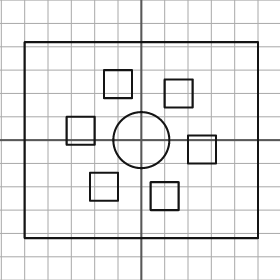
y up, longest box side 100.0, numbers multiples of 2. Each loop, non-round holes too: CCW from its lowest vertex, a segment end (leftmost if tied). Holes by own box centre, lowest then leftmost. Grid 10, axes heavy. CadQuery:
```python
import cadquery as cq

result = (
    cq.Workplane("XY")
    .moveTo(-50.0, -42.0)
    .lineTo(50.0, -42.0)
    .lineTo(50.0, 42.0)
    .lineTo(-50.0, 42.0)
    .close()
    .moveTo(4.0, -30.0)
    .lineTo(16.0, -30.0)
    .lineTo(16.0, -18.0)
    .lineTo(4.0, -18.0)
    .close()
    .moveTo(-22.0, -26.0)
    .lineTo(-10.0, -26.0)
    .lineTo(-10.0, -14.0)
    .lineTo(-22.0, -14.0)
    .close()
    .moveTo(20.0, -10.0)
    .lineTo(32.0, -10.0)
    .lineTo(32.0, 2.0)
    .lineTo(20.0, 2.0)
    .close()
    .moveTo(0.0, 0.0)
    .circle(12.0)
    .moveTo(-32.0, -2.0)
    .lineTo(-20.0, -2.0)
    .lineTo(-20.0, 10.0)
    .lineTo(-32.0, 10.0)
    .close()
    .moveTo(10.0, 14.0)
    .lineTo(22.0, 14.0)
    .lineTo(22.0, 26.0)
    .lineTo(10.0, 26.0)
    .close()
    .moveTo(-16.0, 18.0)
    .lineTo(-4.0, 18.0)
    .lineTo(-4.0, 30.0)
    .lineTo(-16.0, 30.0)
    .close()
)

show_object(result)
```